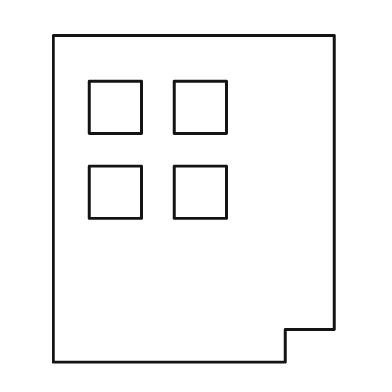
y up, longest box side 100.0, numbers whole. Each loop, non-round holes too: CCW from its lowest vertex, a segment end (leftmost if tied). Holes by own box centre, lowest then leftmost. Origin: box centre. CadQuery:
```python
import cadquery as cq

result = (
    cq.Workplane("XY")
    .moveTo(-43.0, -50.0)
    .lineTo(28.0, -50.0)
    .lineTo(28.0, -40.0)
    .lineTo(43.0, -40.0)
    .lineTo(43.0, 50.0)
    .lineTo(-43.0, 50.0)
    .close()
    .moveTo(-32.0, -6.0)
    .lineTo(-16.0, -6.0)
    .lineTo(-16.0, 10.0)
    .lineTo(-32.0, 10.0)
    .close()
    .moveTo(-6.0, -6.0)
    .lineTo(10.0, -6.0)
    .lineTo(10.0, 10.0)
    .lineTo(-6.0, 10.0)
    .close()
    .moveTo(-32.0, 20.0)
    .lineTo(-16.0, 20.0)
    .lineTo(-16.0, 36.0)
    .lineTo(-32.0, 36.0)
    .close()
    .moveTo(-6.0, 20.0)
    .lineTo(10.0, 20.0)
    .lineTo(10.0, 36.0)
    .lineTo(-6.0, 36.0)
    .close()
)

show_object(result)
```